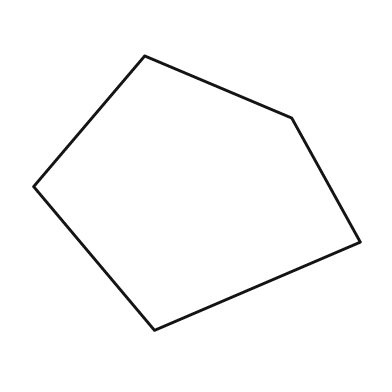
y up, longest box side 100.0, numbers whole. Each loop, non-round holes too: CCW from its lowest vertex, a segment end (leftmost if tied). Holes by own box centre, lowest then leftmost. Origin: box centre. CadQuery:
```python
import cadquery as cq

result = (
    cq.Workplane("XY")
    .moveTo(-13.0, -42.0)
    .lineTo(50.0, -15.0)
    .lineTo(29.0, 23.0)
    .lineTo(-16.0, 42.0)
    .lineTo(-50.0, 2.0)
    .close()
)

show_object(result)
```